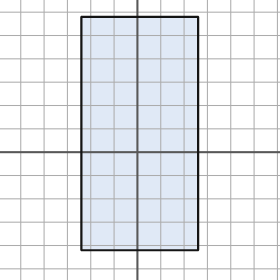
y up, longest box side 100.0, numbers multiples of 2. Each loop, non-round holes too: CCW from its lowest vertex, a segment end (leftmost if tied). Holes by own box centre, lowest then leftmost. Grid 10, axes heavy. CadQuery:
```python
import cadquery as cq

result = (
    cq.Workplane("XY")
    .moveTo(-24.0, -42.0)
    .lineTo(26.0, -42.0)
    .lineTo(26.0, 58.0)
    .lineTo(-24.0, 58.0)
    .close()
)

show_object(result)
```